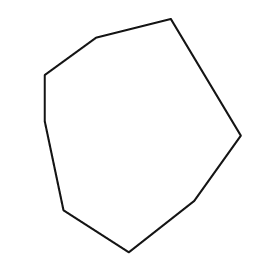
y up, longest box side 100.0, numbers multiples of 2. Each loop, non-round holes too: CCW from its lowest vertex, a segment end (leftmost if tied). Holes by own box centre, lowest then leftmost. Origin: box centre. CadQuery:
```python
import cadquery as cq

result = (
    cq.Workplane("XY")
    .moveTo(-6.0, -50.0)
    .lineTo(22.0, -28.0)
    .lineTo(42.0, 0.0)
    .lineTo(12.0, 50.0)
    .lineTo(-20.0, 42.0)
    .lineTo(-42.0, 26.0)
    .lineTo(-42.0, 6.0)
    .lineTo(-34.0, -32.0)
    .close()
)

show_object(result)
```